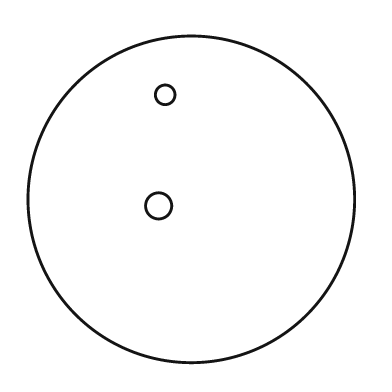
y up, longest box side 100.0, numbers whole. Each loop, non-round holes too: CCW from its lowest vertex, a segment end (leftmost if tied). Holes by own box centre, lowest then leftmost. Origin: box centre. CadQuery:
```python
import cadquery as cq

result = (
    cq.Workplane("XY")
    .moveTo(0.0, 0.0)
    .circle(50.0)
    .moveTo(-10.0, -2.0)
    .circle(4.0)
    .moveTo(-8.0, 32.0)
    .circle(3.0)
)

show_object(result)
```